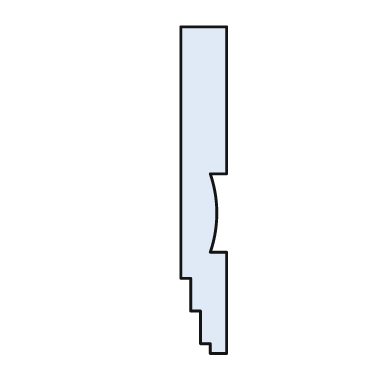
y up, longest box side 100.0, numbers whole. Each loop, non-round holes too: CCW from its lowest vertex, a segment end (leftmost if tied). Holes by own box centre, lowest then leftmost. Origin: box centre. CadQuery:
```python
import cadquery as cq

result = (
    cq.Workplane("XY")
    .moveTo(2.0, -50.0)
    .lineTo(7.0, -50.0)
    .lineTo(7.0, -19.0)
    .lineTo(2.0, -19.0)
    .threePointArc((4.0, -7.0), (2.0, 5.0))
    .lineTo(7.0, 5.0)
    .lineTo(7.0, 50.0)
    .lineTo(-7.0, 50.0)
    .lineTo(-7.0, -27.0)
    .lineTo(-4.0, -27.0)
    .lineTo(-4.0, -37.0)
    .lineTo(-1.0, -37.0)
    .lineTo(-1.0, -47.0)
    .lineTo(2.0, -47.0)
    .close()
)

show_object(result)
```